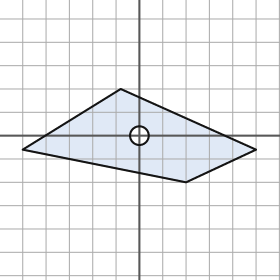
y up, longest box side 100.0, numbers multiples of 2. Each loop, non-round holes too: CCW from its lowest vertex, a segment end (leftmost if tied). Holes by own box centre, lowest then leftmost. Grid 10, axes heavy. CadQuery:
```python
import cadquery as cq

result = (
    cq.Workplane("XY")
    .moveTo(20.0, -20.0)
    .lineTo(50.0, -6.0)
    .lineTo(-8.0, 20.0)
    .lineTo(-50.0, -6.0)
    .close()
    .moveTo(0.0, 0.0)
    .circle(4.0)
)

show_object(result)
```